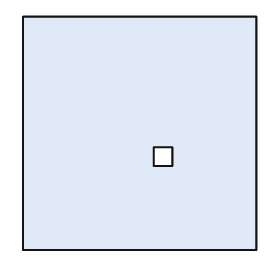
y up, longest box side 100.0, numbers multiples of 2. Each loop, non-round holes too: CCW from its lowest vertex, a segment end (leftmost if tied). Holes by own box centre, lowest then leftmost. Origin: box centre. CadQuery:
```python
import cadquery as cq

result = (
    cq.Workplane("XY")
    .moveTo(-50.0, -50.0)
    .lineTo(50.0, -50.0)
    .lineTo(50.0, 50.0)
    .lineTo(-50.0, 50.0)
    .close()
    .moveTo(6.0, -14.0)
    .lineTo(14.0, -14.0)
    .lineTo(14.0, -6.0)
    .lineTo(6.0, -6.0)
    .close()
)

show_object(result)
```